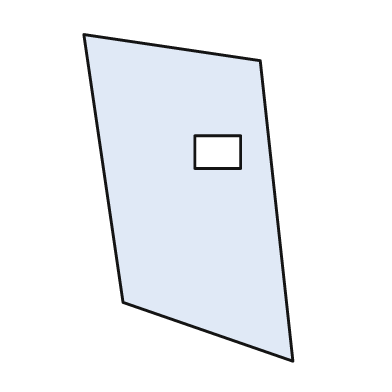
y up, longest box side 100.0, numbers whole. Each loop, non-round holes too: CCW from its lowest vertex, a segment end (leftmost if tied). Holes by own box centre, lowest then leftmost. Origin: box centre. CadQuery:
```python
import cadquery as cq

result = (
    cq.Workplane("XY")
    .moveTo(32.0, -50.0)
    .lineTo(22.0, 42.0)
    .lineTo(-32.0, 50.0)
    .lineTo(-20.0, -32.0)
    .close()
    .moveTo(2.0, 9.0)
    .lineTo(16.0, 9.0)
    .lineTo(16.0, 19.0)
    .lineTo(2.0, 19.0)
    .close()
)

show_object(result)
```